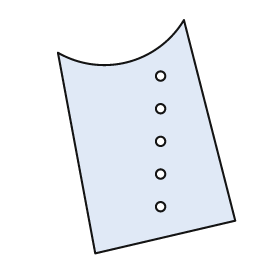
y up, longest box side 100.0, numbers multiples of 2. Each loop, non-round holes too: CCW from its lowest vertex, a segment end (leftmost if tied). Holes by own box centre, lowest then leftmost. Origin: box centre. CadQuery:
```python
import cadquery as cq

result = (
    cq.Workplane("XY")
    .moveTo(-22.0, -50.0)
    .lineTo(38.0, -36.0)
    .lineTo(16.0, 50.0)
    .threePointArc((-8.0, 32.0), (-38.0, 36.0))
    .close()
    .moveTo(6.0, -30.0)
    .circle(2.0)
    .moveTo(6.0, -16.0)
    .circle(2.0)
    .moveTo(6.0, -2.0)
    .circle(2.0)
    .moveTo(6.0, 12.0)
    .circle(2.0)
    .moveTo(6.0, 26.0)
    .circle(2.0)
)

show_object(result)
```